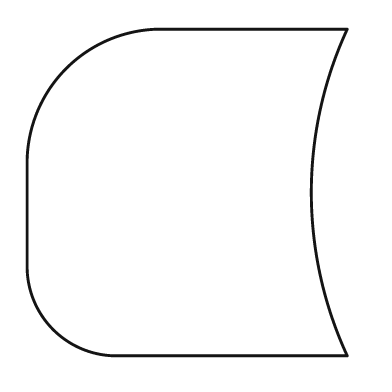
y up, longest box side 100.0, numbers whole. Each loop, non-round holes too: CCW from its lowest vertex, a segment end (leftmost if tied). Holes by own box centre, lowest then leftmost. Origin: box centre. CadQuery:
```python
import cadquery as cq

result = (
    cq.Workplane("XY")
    .moveTo(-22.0, -50.0)
    .lineTo(49.0, -50.0)
    .threePointArc((38.0, 0.0), (49.0, 50.0))
    .lineTo(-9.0, 50.0)
    .threePointArc((-37.0, 38.0), (-49.0, 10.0))
    .lineTo(-49.0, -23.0)
    .threePointArc((-41.0, -42.0), (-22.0, -50.0))
    .close()
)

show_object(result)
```